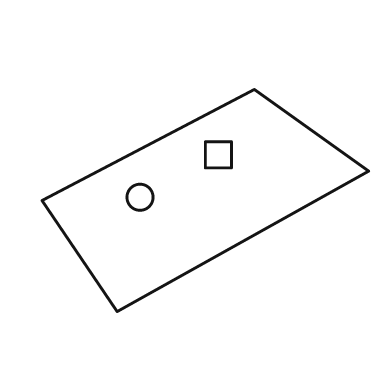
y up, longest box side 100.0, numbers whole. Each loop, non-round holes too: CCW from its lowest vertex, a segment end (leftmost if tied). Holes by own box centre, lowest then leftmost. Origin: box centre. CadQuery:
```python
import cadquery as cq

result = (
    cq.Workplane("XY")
    .moveTo(-27.0, -34.0)
    .lineTo(50.0, 9.0)
    .lineTo(15.0, 34.0)
    .lineTo(-50.0, 0.0)
    .close()
    .moveTo(-20.0, 1.0)
    .circle(4.0)
    .moveTo(0.0, 10.0)
    .lineTo(8.0, 10.0)
    .lineTo(8.0, 18.0)
    .lineTo(0.0, 18.0)
    .close()
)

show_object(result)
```